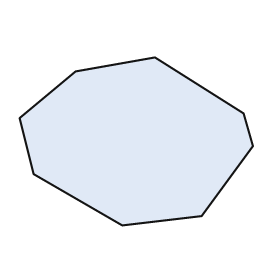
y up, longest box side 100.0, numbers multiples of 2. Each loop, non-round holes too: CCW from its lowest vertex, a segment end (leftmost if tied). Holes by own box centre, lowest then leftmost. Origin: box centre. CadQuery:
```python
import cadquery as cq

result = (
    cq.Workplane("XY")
    .moveTo(-6.0, -36.0)
    .lineTo(28.0, -32.0)
    .lineTo(50.0, -2.0)
    .lineTo(46.0, 12.0)
    .lineTo(8.0, 36.0)
    .lineTo(-26.0, 30.0)
    .lineTo(-50.0, 10.0)
    .lineTo(-44.0, -14.0)
    .close()
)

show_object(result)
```